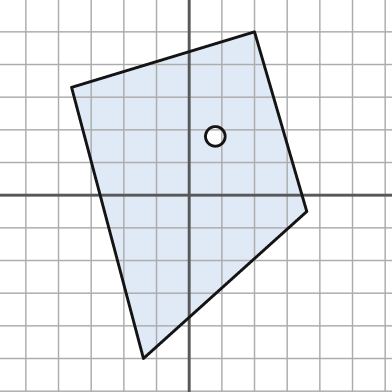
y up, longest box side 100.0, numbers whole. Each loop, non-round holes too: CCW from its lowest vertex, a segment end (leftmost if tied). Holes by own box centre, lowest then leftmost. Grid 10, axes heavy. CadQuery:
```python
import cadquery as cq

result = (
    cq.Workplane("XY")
    .moveTo(-14.0, -50.0)
    .lineTo(36.0, -5.0)
    .lineTo(20.0, 50.0)
    .lineTo(-36.0, 33.0)
    .close()
    .moveTo(8.0, 18.0)
    .circle(3.0)
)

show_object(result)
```